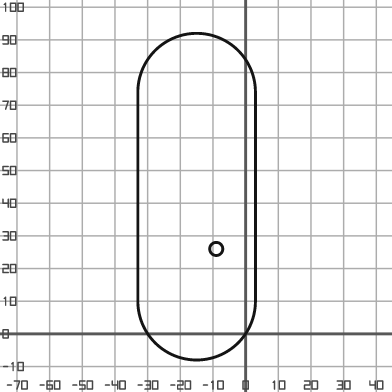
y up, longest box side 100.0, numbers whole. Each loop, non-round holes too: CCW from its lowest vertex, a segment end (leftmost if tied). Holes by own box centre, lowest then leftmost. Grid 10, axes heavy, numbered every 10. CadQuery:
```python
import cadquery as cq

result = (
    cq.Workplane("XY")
    .moveTo(-33.0, 10.0)
    .threePointArc((-15.0, -8.0), (3.0, 10.0))
    .lineTo(3.0, 74.0)
    .threePointArc((-15.0, 92.0), (-33.0, 74.0))
    .close()
    .moveTo(-9.0, 26.0)
    .circle(2.0)
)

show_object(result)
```